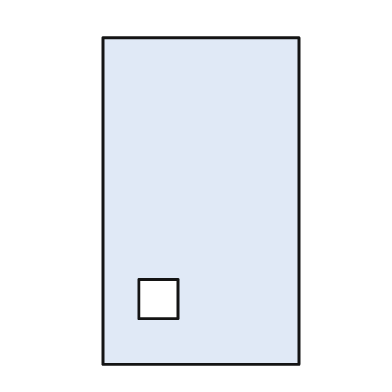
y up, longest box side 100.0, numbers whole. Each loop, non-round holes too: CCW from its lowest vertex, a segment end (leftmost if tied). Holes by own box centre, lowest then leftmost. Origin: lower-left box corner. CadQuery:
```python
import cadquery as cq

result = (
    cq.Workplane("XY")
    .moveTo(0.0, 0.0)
    .lineTo(60.0, 0.0)
    .lineTo(60.0, 100.0)
    .lineTo(0.0, 100.0)
    .close()
    .moveTo(11.0, 14.0)
    .lineTo(23.0, 14.0)
    .lineTo(23.0, 26.0)
    .lineTo(11.0, 26.0)
    .close()
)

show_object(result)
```